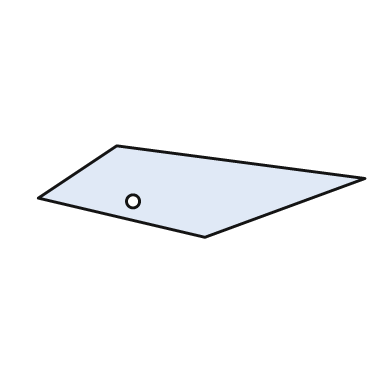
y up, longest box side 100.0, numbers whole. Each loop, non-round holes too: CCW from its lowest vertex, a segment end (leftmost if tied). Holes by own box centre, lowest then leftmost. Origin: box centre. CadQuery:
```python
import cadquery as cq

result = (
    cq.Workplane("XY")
    .moveTo(1.0, -14.0)
    .lineTo(50.0, 4.0)
    .lineTo(-26.0, 14.0)
    .lineTo(-50.0, -2.0)
    .close()
    .moveTo(-21.0, -3.0)
    .circle(2.0)
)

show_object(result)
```